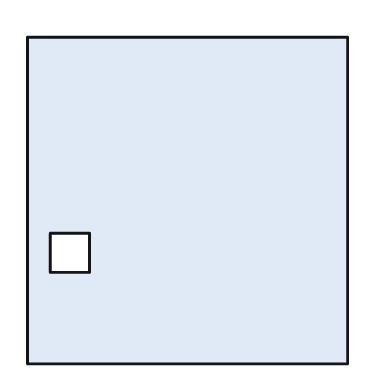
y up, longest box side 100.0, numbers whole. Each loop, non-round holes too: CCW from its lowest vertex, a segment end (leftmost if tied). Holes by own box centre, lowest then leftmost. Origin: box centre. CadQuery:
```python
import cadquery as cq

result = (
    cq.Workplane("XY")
    .moveTo(-49.0, -50.0)
    .lineTo(49.0, -50.0)
    .lineTo(49.0, 50.0)
    .lineTo(-49.0, 50.0)
    .close()
    .moveTo(-42.0, -22.0)
    .lineTo(-30.0, -22.0)
    .lineTo(-30.0, -10.0)
    .lineTo(-42.0, -10.0)
    .close()
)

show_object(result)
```